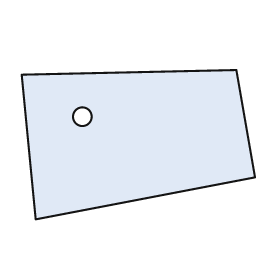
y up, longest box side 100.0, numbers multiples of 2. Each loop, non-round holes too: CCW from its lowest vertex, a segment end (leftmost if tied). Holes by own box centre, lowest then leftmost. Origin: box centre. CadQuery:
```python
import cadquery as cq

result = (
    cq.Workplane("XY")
    .moveTo(-44.0, -32.0)
    .lineTo(50.0, -14.0)
    .lineTo(42.0, 32.0)
    .lineTo(-50.0, 30.0)
    .close()
    .moveTo(-24.0, 12.0)
    .circle(4.0)
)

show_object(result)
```